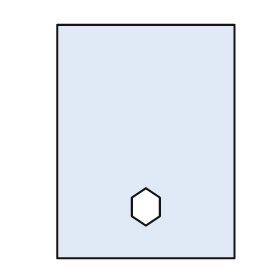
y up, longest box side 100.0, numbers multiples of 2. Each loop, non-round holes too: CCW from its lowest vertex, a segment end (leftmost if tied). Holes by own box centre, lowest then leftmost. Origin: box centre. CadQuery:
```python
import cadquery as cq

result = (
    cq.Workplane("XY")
    .moveTo(-38.0, -50.0)
    .lineTo(38.0, -50.0)
    .lineTo(38.0, 50.0)
    .lineTo(-38.0, 50.0)
    .close()
    .moveTo(0.0, -36.0)
    .lineTo(6.0, -32.0)
    .lineTo(6.0, -24.0)
    .lineTo(0.0, -20.0)
    .lineTo(-6.0, -24.0)
    .lineTo(-6.0, -32.0)
    .close()
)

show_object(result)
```